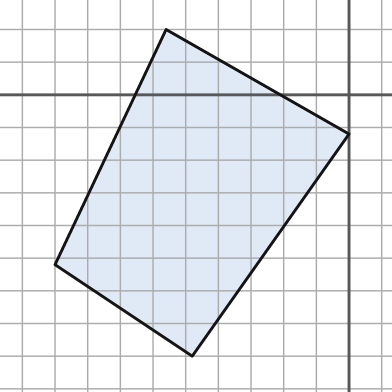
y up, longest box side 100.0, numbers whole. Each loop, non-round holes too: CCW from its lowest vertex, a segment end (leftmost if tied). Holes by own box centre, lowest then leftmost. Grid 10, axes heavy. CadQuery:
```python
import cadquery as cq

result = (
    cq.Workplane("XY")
    .moveTo(-48.0, -80.0)
    .lineTo(0.0, -12.0)
    .lineTo(-56.0, 20.0)
    .lineTo(-90.0, -52.0)
    .close()
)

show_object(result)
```